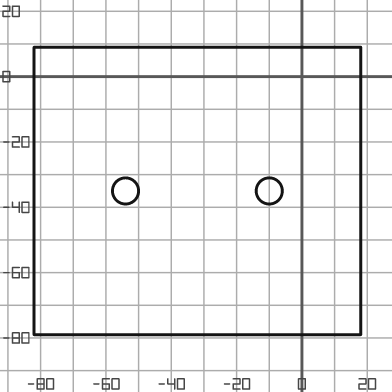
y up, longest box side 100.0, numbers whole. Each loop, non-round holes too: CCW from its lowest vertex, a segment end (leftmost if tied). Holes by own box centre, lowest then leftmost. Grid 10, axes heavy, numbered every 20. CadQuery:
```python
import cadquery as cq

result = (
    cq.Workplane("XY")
    .moveTo(-82.0, -79.0)
    .lineTo(18.0, -79.0)
    .lineTo(18.0, 9.0)
    .lineTo(-82.0, 9.0)
    .close()
    .moveTo(-54.0, -35.0)
    .circle(4.0)
    .moveTo(-10.0, -35.0)
    .circle(4.0)
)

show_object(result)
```